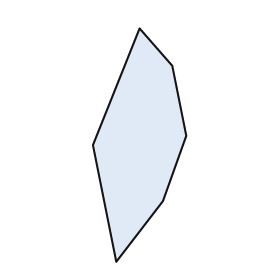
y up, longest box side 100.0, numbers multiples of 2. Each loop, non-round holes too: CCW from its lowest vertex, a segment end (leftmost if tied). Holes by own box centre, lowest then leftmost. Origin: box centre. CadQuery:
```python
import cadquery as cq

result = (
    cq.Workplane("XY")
    .moveTo(-10.0, -50.0)
    .lineTo(10.0, -24.0)
    .lineTo(20.0, 4.0)
    .lineTo(14.0, 34.0)
    .lineTo(0.0, 50.0)
    .lineTo(-20.0, 0.0)
    .close()
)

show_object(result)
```